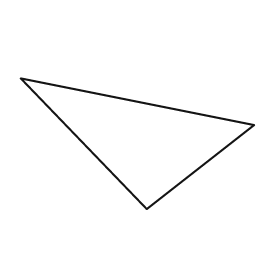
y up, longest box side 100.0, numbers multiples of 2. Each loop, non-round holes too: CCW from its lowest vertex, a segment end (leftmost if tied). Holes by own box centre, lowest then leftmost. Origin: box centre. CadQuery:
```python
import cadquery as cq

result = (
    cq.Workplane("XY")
    .moveTo(4.0, -28.0)
    .lineTo(50.0, 8.0)
    .lineTo(-50.0, 28.0)
    .close()
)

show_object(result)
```